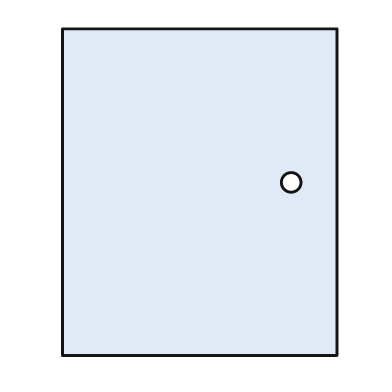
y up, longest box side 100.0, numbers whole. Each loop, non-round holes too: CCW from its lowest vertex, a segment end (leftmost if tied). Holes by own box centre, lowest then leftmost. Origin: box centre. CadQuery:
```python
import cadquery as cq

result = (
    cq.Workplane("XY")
    .moveTo(-42.0, -50.0)
    .lineTo(42.0, -50.0)
    .lineTo(42.0, 50.0)
    .lineTo(-42.0, 50.0)
    .close()
    .moveTo(28.0, 3.0)
    .circle(3.0)
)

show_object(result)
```